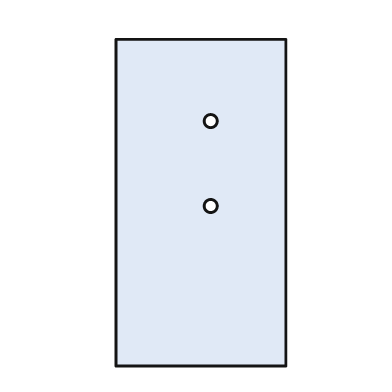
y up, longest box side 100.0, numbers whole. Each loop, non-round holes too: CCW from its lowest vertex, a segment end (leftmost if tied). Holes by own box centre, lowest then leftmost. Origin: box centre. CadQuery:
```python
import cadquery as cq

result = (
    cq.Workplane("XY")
    .moveTo(-26.0, -50.0)
    .lineTo(26.0, -50.0)
    .lineTo(26.0, 50.0)
    .lineTo(-26.0, 50.0)
    .close()
    .moveTo(3.0, -1.0)
    .circle(2.0)
    .moveTo(3.0, 25.0)
    .circle(2.0)
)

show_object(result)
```